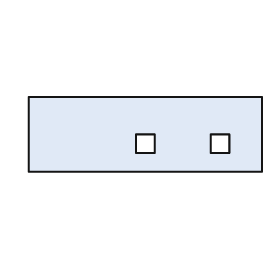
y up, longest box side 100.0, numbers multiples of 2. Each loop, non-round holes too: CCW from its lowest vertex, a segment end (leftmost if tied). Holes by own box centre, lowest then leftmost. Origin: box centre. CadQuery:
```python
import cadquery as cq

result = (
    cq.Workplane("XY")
    .moveTo(-50.0, -16.0)
    .lineTo(50.0, -16.0)
    .lineTo(50.0, 16.0)
    .lineTo(-50.0, 16.0)
    .close()
    .moveTo(-4.0, -8.0)
    .lineTo(4.0, -8.0)
    .lineTo(4.0, 0.0)
    .lineTo(-4.0, 0.0)
    .close()
    .moveTo(28.0, -8.0)
    .lineTo(36.0, -8.0)
    .lineTo(36.0, 0.0)
    .lineTo(28.0, 0.0)
    .close()
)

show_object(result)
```